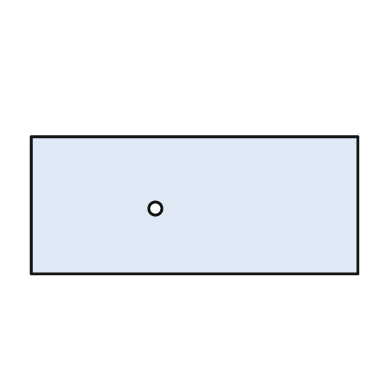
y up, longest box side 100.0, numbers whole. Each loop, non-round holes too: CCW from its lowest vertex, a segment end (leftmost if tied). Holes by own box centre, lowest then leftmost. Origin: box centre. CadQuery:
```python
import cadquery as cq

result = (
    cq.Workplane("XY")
    .moveTo(-50.0, -21.0)
    .lineTo(50.0, -21.0)
    .lineTo(50.0, 21.0)
    .lineTo(-50.0, 21.0)
    .close()
    .moveTo(-12.0, -1.0)
    .circle(2.0)
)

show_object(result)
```